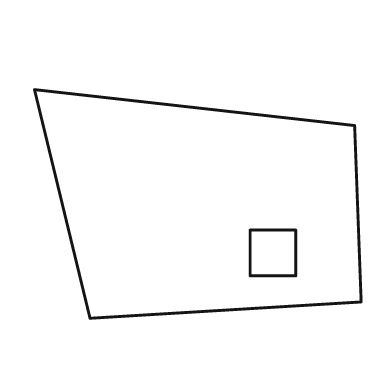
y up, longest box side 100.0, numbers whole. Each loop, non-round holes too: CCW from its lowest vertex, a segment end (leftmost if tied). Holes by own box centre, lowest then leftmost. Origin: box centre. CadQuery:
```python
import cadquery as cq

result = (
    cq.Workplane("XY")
    .moveTo(-33.0, -35.0)
    .lineTo(50.0, -30.0)
    .lineTo(48.0, 24.0)
    .lineTo(-50.0, 35.0)
    .close()
    .moveTo(16.0, -22.0)
    .lineTo(30.0, -22.0)
    .lineTo(30.0, -8.0)
    .lineTo(16.0, -8.0)
    .close()
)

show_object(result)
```